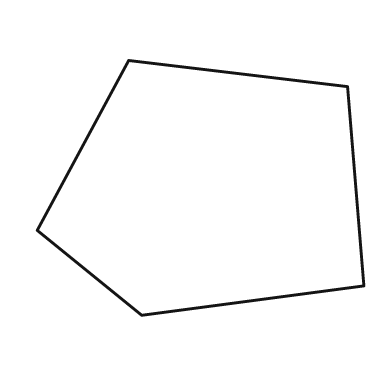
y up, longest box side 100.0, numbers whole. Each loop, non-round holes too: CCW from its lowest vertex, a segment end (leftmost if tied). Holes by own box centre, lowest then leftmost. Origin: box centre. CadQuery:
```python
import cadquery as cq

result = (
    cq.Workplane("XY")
    .moveTo(-18.0, -39.0)
    .lineTo(50.0, -30.0)
    .lineTo(45.0, 31.0)
    .lineTo(-22.0, 39.0)
    .lineTo(-50.0, -13.0)
    .close()
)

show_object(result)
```